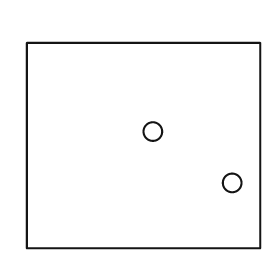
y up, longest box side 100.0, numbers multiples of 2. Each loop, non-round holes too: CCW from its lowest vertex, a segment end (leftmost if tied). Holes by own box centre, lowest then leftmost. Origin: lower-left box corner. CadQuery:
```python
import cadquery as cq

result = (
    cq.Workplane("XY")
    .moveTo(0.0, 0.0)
    .lineTo(100.0, 0.0)
    .lineTo(100.0, 88.0)
    .lineTo(0.0, 88.0)
    .close()
    .moveTo(88.0, 28.0)
    .circle(4.0)
    .moveTo(54.0, 50.0)
    .circle(4.0)
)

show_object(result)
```